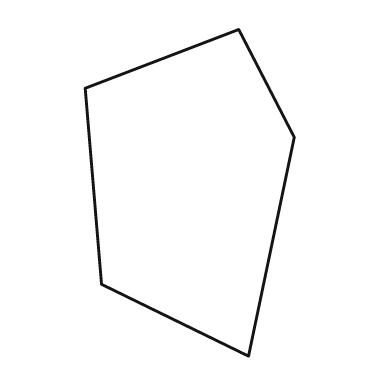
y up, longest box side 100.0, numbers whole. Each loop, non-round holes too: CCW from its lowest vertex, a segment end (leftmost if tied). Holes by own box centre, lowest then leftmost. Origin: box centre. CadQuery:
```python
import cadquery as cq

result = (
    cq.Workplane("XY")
    .moveTo(18.0, -50.0)
    .lineTo(32.0, 17.0)
    .lineTo(15.0, 50.0)
    .lineTo(-32.0, 32.0)
    .lineTo(-27.0, -28.0)
    .close()
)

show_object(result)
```